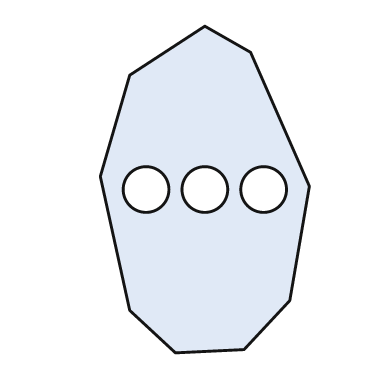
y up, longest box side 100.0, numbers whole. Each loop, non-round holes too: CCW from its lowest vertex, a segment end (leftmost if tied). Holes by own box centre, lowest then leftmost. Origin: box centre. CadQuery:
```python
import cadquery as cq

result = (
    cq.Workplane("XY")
    .moveTo(-9.0, -50.0)
    .lineTo(12.0, -49.0)
    .lineTo(26.0, -34.0)
    .lineTo(32.0, 1.0)
    .lineTo(14.0, 42.0)
    .lineTo(0.0, 50.0)
    .lineTo(-23.0, 35.0)
    .lineTo(-32.0, 4.0)
    .lineTo(-23.0, -37.0)
    .close()
    .moveTo(-18.0, 0.0)
    .circle(7.0)
    .moveTo(0.0, 0.0)
    .circle(7.0)
    .moveTo(18.0, 0.0)
    .circle(7.0)
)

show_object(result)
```